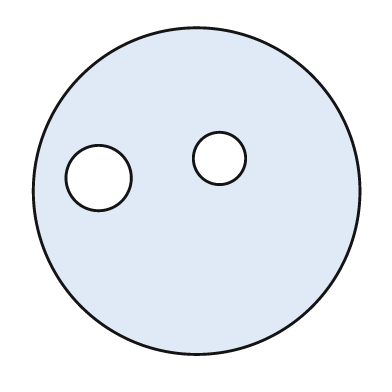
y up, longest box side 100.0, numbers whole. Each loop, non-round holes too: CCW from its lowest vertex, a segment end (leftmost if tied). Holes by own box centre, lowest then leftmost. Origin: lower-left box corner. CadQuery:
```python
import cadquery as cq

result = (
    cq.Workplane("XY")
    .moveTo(50.0, 50.0)
    .circle(50.0)
    .moveTo(20.0, 54.0)
    .circle(10.0)
    .moveTo(57.0, 60.0)
    .circle(8.0)
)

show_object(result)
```